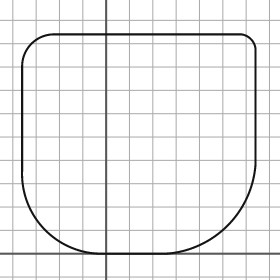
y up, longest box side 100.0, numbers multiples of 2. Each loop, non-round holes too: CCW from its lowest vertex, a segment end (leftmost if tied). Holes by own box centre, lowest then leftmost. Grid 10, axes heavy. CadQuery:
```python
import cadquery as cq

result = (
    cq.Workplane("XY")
    .moveTo(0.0, 0.0)
    .lineTo(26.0, 0.0)
    .threePointArc((52.0, 12.0), (64.0, 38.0))
    .lineTo(64.0, 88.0)
    .threePointArc((62.0, 92.0), (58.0, 94.0))
    .lineTo(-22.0, 94.0)
    .threePointArc((-32.0, 90.0), (-36.0, 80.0))
    .lineTo(-36.0, 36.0)
    .threePointArc((-26.0, 10.0), (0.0, 0.0))
    .close()
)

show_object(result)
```